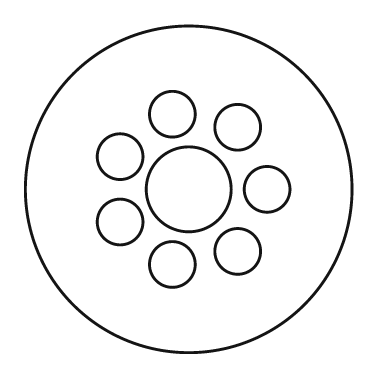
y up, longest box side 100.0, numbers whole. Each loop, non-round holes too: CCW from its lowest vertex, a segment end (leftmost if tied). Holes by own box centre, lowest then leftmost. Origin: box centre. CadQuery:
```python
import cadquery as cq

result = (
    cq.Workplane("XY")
    .moveTo(0.0, 0.0)
    .circle(50.0)
    .moveTo(-5.0, -23.0)
    .circle(7.0)
    .moveTo(15.0, -19.0)
    .circle(7.0)
    .moveTo(-21.0, -10.0)
    .circle(7.0)
    .moveTo(0.0, 0.0)
    .circle(13.0)
    .moveTo(24.0, 0.0)
    .circle(7.0)
    .moveTo(-21.0, 10.0)
    .circle(7.0)
    .moveTo(15.0, 19.0)
    .circle(7.0)
    .moveTo(-5.0, 23.0)
    .circle(7.0)
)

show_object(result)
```